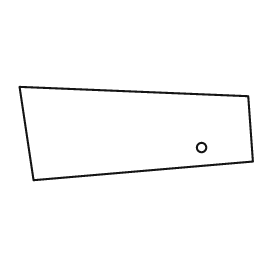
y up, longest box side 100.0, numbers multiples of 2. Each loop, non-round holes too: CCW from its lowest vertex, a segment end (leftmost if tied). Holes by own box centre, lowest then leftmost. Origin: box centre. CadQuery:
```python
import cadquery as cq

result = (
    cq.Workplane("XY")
    .moveTo(-44.0, -20.0)
    .lineTo(50.0, -12.0)
    .lineTo(48.0, 16.0)
    .lineTo(-50.0, 20.0)
    .close()
    .moveTo(28.0, -6.0)
    .circle(2.0)
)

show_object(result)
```